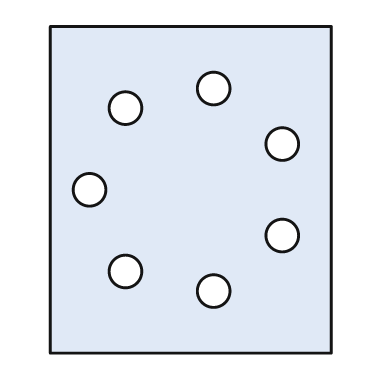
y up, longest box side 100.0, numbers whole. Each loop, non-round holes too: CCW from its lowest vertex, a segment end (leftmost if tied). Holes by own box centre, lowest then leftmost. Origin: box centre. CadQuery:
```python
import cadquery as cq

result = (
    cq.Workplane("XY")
    .moveTo(-43.0, -50.0)
    .lineTo(43.0, -50.0)
    .lineTo(43.0, 50.0)
    .lineTo(-43.0, 50.0)
    .close()
    .moveTo(7.0, -31.0)
    .circle(5.0)
    .moveTo(-20.0, -25.0)
    .circle(5.0)
    .moveTo(28.0, -14.0)
    .circle(5.0)
    .moveTo(-31.0, 0.0)
    .circle(5.0)
    .moveTo(28.0, 14.0)
    .circle(5.0)
    .moveTo(-20.0, 25.0)
    .circle(5.0)
    .moveTo(7.0, 31.0)
    .circle(5.0)
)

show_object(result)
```